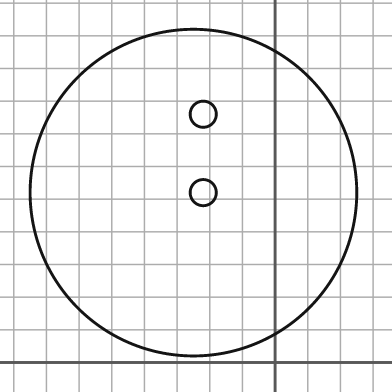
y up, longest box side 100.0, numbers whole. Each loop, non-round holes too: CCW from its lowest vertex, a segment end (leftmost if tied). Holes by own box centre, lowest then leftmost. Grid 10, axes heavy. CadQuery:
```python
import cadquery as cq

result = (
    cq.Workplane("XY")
    .moveTo(-25.0, 52.0)
    .circle(50.0)
    .moveTo(-22.0, 52.0)
    .circle(4.0)
    .moveTo(-22.0, 76.0)
    .circle(4.0)
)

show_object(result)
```